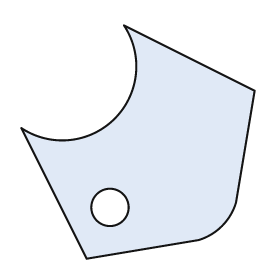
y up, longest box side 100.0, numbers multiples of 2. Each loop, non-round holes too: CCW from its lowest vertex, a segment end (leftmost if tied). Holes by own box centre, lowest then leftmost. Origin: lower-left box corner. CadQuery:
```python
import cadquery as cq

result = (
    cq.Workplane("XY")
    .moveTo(28.0, 0.0)
    .lineTo(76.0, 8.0)
    .threePointArc((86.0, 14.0), (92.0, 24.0))
    .lineTo(100.0, 72.0)
    .lineTo(44.0, 100.0)
    .threePointArc((40.0, 60.0), (0.0, 56.0))
    .close()
    .moveTo(38.0, 22.0)
    .circle(8.0)
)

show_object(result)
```